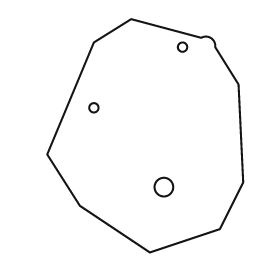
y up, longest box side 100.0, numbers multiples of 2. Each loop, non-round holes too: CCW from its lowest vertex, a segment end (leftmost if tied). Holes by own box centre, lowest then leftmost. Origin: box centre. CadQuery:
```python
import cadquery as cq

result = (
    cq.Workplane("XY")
    .moveTo(2.0, -50.0)
    .lineTo(32.0, -40.0)
    .lineTo(42.0, -20.0)
    .lineTo(40.0, 22.0)
    .lineTo(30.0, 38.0)
    .threePointArc((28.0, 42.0), (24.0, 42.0))
    .lineTo(-6.0, 50.0)
    .lineTo(-22.0, 40.0)
    .lineTo(-42.0, -8.0)
    .lineTo(-28.0, -30.0)
    .close()
    .moveTo(8.0, -22.0)
    .circle(4.0)
    .moveTo(-22.0, 12.0)
    .circle(2.0)
    .moveTo(16.0, 38.0)
    .circle(2.0)
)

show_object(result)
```